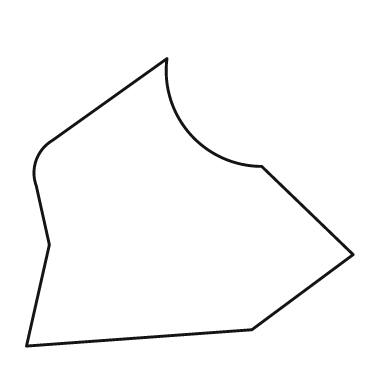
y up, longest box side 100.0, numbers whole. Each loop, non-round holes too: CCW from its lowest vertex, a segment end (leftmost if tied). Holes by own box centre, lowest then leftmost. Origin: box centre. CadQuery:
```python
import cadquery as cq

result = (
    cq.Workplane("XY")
    .moveTo(-50.0, -44.0)
    .lineTo(19.0, -39.0)
    .lineTo(50.0, -16.0)
    .lineTo(22.0, 11.0)
    .threePointArc((0.0, 21.0), (-7.0, 44.0))
    .lineTo(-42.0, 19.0)
    .threePointArc((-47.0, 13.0), (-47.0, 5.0))
    .lineTo(-43.0, -13.0)
    .close()
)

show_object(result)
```